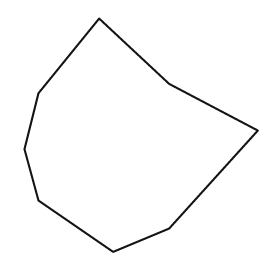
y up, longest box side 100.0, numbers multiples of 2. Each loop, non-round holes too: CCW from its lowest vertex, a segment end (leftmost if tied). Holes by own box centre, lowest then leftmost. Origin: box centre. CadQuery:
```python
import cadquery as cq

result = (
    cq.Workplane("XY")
    .moveTo(-12.0, -50.0)
    .lineTo(12.0, -40.0)
    .lineTo(50.0, 2.0)
    .lineTo(12.0, 22.0)
    .lineTo(-18.0, 50.0)
    .lineTo(-44.0, 18.0)
    .lineTo(-50.0, -6.0)
    .lineTo(-44.0, -28.0)
    .close()
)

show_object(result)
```